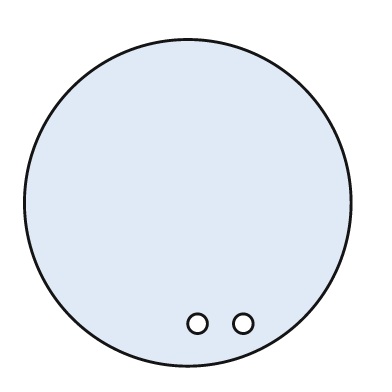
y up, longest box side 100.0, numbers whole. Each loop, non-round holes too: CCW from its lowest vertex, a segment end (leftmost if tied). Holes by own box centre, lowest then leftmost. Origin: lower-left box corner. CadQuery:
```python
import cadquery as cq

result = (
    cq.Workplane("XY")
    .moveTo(50.0, 50.0)
    .circle(50.0)
    .moveTo(53.0, 13.0)
    .circle(3.0)
    .moveTo(67.0, 13.0)
    .circle(3.0)
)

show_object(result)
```